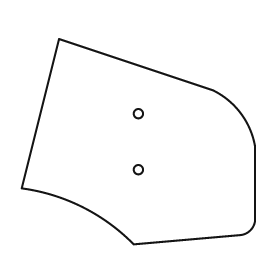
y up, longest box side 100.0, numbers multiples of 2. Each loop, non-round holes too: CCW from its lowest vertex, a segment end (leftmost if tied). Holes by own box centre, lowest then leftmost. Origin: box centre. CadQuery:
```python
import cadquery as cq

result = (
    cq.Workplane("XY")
    .moveTo(-2.0, -44.0)
    .lineTo(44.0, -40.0)
    .threePointArc((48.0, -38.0), (50.0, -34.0))
    .lineTo(50.0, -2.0)
    .threePointArc((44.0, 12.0), (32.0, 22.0))
    .lineTo(-34.0, 44.0)
    .lineTo(-50.0, -20.0)
    .threePointArc((-24.0, -28.0), (-2.0, -44.0))
    .close()
    .moveTo(0.0, -12.0)
    .circle(2.0)
    .moveTo(0.0, 12.0)
    .circle(2.0)
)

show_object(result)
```